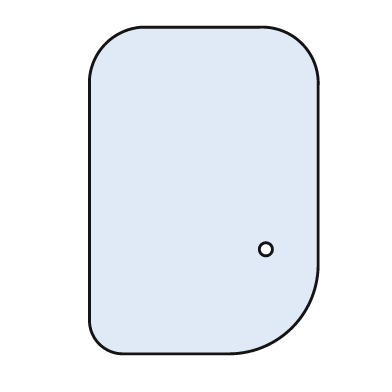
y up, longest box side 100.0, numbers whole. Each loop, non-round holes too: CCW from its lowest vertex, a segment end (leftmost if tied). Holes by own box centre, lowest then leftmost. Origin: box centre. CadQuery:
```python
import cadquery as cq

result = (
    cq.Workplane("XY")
    .moveTo(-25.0, -50.0)
    .lineTo(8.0, -50.0)
    .threePointArc((27.0, -42.0), (35.0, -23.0))
    .lineTo(35.0, 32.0)
    .threePointArc((30.0, 45.0), (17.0, 50.0))
    .lineTo(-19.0, 50.0)
    .threePointArc((-30.0, 45.0), (-35.0, 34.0))
    .lineTo(-35.0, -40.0)
    .threePointArc((-32.0, -47.0), (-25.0, -50.0))
    .close()
    .moveTo(19.0, -18.0)
    .circle(2.0)
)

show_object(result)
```